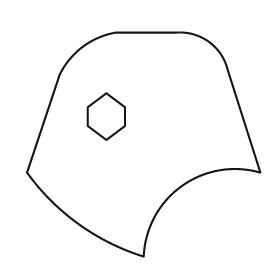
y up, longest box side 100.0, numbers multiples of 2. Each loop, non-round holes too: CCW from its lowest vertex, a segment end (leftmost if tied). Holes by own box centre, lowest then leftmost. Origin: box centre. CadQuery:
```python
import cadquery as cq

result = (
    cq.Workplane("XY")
    .moveTo(0.0, -48.0)
    .threePointArc((16.0, -18.0), (50.0, -12.0))
    .lineTo(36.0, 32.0)
    .threePointArc((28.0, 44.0), (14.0, 48.0))
    .lineTo(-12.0, 48.0)
    .threePointArc((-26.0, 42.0), (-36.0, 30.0))
    .lineTo(-50.0, -12.0)
    .threePointArc((-28.0, -34.0), (0.0, -48.0))
    .close()
    .moveTo(-16.0, 2.0)
    .lineTo(-8.0, 8.0)
    .lineTo(-8.0, 16.0)
    .lineTo(-16.0, 22.0)
    .lineTo(-24.0, 16.0)
    .lineTo(-24.0, 8.0)
    .close()
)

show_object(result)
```